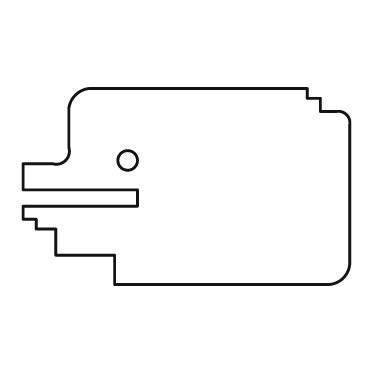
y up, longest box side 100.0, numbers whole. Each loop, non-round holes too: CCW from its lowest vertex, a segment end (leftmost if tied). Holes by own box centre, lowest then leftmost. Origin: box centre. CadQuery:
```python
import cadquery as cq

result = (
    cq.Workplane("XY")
    .moveTo(-22.0, -30.0)
    .lineTo(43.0, -30.0)
    .threePointArc((48.0, -28.0), (50.0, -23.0))
    .lineTo(50.0, 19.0)
    .threePointArc((49.0, 22.0), (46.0, 23.0))
    .lineTo(41.0, 23.0)
    .lineTo(41.0, 27.0)
    .lineTo(37.0, 27.0)
    .lineTo(37.0, 30.0)
    .lineTo(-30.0, 30.0)
    .threePointArc((-34.0, 28.0), (-36.0, 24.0))
    .lineTo(-36.0, 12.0)
    .threePointArc((-37.0, 8.0), (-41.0, 7.0))
    .lineTo(-50.0, 7.0)
    .lineTo(-50.0, -1.0)
    .lineTo(-15.0, -1.0)
    .lineTo(-15.0, -6.0)
    .lineTo(-50.0, -6.0)
    .lineTo(-50.0, -10.0)
    .lineTo(-46.0, -10.0)
    .lineTo(-46.0, -13.0)
    .lineTo(-40.0, -13.0)
    .lineTo(-40.0, -21.0)
    .lineTo(-22.0, -21.0)
    .close()
    .moveTo(-18.0, 8.0)
    .circle(3.0)
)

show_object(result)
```